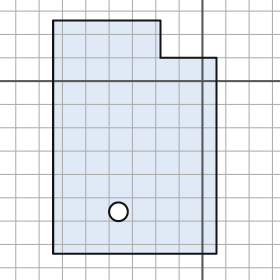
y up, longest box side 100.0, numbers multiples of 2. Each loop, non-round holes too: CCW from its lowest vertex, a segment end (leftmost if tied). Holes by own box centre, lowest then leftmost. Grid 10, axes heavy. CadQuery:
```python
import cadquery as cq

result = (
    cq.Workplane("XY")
    .moveTo(-64.0, -74.0)
    .lineTo(6.0, -74.0)
    .lineTo(6.0, 10.0)
    .lineTo(-18.0, 10.0)
    .lineTo(-18.0, 26.0)
    .lineTo(-64.0, 26.0)
    .close()
    .moveTo(-36.0, -56.0)
    .circle(4.0)
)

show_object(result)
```